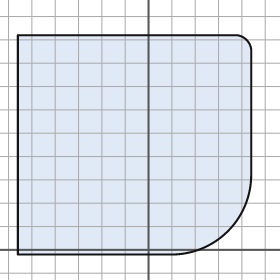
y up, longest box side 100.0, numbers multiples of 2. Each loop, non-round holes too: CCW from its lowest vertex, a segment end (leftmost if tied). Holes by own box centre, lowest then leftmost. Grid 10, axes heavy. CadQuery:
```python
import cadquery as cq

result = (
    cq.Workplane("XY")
    .moveTo(-56.0, -2.0)
    .lineTo(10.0, -2.0)
    .threePointArc((34.0, 8.0), (44.0, 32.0))
    .lineTo(44.0, 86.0)
    .threePointArc((42.0, 90.0), (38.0, 92.0))
    .lineTo(-56.0, 92.0)
    .close()
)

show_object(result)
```